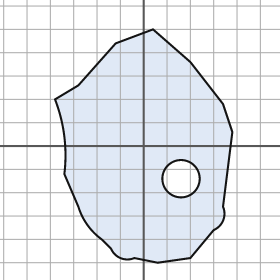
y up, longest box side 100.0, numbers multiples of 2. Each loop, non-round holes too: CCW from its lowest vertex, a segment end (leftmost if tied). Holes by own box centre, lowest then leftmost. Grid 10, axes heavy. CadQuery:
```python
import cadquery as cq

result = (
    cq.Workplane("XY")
    .moveTo(6.0, -50.0)
    .lineTo(20.0, -48.0)
    .lineTo(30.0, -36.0)
    .threePointArc((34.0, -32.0), (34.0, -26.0))
    .lineTo(38.0, 6.0)
    .lineTo(34.0, 18.0)
    .lineTo(20.0, 36.0)
    .lineTo(4.0, 50.0)
    .lineTo(-12.0, 44.0)
    .lineTo(-28.0, 26.0)
    .lineTo(-38.0, 20.0)
    .threePointArc((-34.0, 4.0), (-34.0, -12.0))
    .lineTo(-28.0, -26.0)
    .threePointArc((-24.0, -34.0), (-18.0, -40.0))
    .lineTo(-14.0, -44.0)
    .threePointArc((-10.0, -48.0), (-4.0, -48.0))
    .close()
    .moveTo(16.0, -14.0)
    .circle(8.0)
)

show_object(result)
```